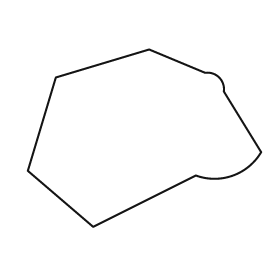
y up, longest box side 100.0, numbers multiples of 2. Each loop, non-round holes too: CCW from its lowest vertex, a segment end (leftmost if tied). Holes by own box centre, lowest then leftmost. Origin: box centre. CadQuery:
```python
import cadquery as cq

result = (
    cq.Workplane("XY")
    .moveTo(-22.0, -38.0)
    .lineTo(22.0, -16.0)
    .threePointArc((38.0, -16.0), (50.0, -6.0))
    .lineTo(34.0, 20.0)
    .threePointArc((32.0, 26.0), (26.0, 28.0))
    .lineTo(2.0, 38.0)
    .lineTo(-38.0, 26.0)
    .lineTo(-50.0, -14.0)
    .close()
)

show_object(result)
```